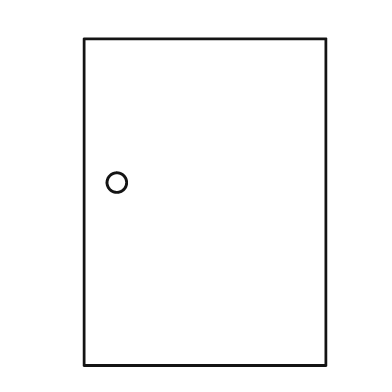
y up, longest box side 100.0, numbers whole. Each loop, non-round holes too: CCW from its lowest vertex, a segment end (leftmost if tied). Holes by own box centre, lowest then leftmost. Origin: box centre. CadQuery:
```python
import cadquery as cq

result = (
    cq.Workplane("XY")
    .moveTo(-37.0, -50.0)
    .lineTo(37.0, -50.0)
    .lineTo(37.0, 50.0)
    .lineTo(-37.0, 50.0)
    .close()
    .moveTo(-27.0, 6.0)
    .circle(3.0)
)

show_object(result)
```